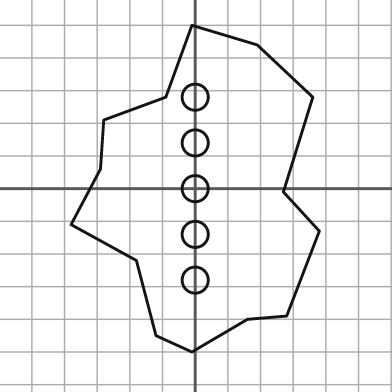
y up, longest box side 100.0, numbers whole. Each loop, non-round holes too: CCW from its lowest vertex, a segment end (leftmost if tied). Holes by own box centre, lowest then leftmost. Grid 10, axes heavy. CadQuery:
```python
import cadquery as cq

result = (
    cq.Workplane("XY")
    .moveTo(-1.0, -50.0)
    .lineTo(16.0, -40.0)
    .lineTo(28.0, -39.0)
    .lineTo(38.0, -13.0)
    .lineTo(27.0, -1.0)
    .lineTo(36.0, 28.0)
    .lineTo(19.0, 44.0)
    .lineTo(-1.0, 50.0)
    .lineTo(-9.0, 28.0)
    .lineTo(-28.0, 21.0)
    .lineTo(-29.0, 6.0)
    .lineTo(-38.0, -11.0)
    .lineTo(-18.0, -22.0)
    .lineTo(-12.0, -45.0)
    .close()
    .moveTo(0.0, -28.0)
    .circle(4.0)
    .moveTo(0.0, -14.0)
    .circle(4.0)
    .moveTo(0.0, 0.0)
    .circle(4.0)
    .moveTo(0.0, 14.0)
    .circle(4.0)
    .moveTo(0.0, 28.0)
    .circle(4.0)
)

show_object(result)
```